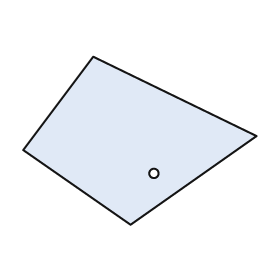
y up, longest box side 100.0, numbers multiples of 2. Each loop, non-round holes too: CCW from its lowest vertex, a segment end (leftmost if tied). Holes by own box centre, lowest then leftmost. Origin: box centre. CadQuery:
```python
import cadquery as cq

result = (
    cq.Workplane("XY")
    .moveTo(-4.0, -36.0)
    .lineTo(50.0, 2.0)
    .lineTo(-20.0, 36.0)
    .lineTo(-50.0, -4.0)
    .close()
    .moveTo(6.0, -14.0)
    .circle(2.0)
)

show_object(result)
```